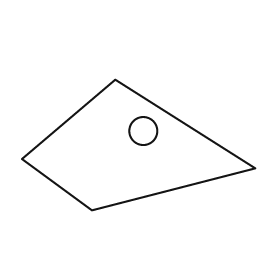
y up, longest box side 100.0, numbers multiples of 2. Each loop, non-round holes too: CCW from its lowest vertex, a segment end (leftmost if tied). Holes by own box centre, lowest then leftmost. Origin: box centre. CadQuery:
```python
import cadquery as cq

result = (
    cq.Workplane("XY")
    .moveTo(-20.0, -28.0)
    .lineTo(50.0, -10.0)
    .lineTo(-10.0, 28.0)
    .lineTo(-50.0, -6.0)
    .close()
    .moveTo(2.0, 6.0)
    .circle(6.0)
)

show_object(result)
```